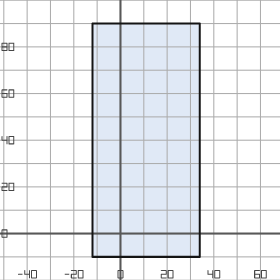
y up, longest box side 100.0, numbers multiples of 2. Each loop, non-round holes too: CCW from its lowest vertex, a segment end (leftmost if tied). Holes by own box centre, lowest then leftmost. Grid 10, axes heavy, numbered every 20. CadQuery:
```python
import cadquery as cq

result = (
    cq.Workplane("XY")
    .moveTo(-12.0, -10.0)
    .lineTo(34.0, -10.0)
    .lineTo(34.0, 90.0)
    .lineTo(-12.0, 90.0)
    .close()
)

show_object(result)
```